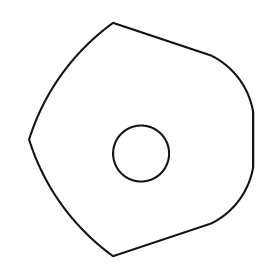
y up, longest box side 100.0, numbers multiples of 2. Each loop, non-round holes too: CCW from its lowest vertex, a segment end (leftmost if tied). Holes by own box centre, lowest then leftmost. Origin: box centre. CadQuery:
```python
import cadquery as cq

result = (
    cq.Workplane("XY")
    .moveTo(-12.0, -50.0)
    .lineTo(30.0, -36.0)
    .threePointArc((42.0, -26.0), (48.0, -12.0))
    .lineTo(48.0, 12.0)
    .threePointArc((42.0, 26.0), (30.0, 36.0))
    .lineTo(-12.0, 50.0)
    .threePointArc((-34.0, 28.0), (-48.0, 0.0))
    .threePointArc((-34.0, -28.0), (-12.0, -50.0))
    .close()
    .moveTo(0.0, -6.0)
    .circle(12.0)
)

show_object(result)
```